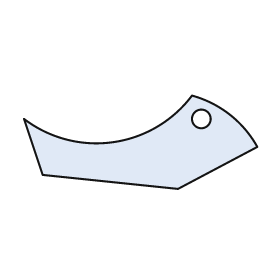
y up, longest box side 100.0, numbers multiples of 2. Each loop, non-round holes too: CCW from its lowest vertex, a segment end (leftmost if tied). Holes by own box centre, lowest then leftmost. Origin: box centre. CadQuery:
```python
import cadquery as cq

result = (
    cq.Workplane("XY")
    .moveTo(16.0, -20.0)
    .lineTo(50.0, -2.0)
    .threePointArc((38.0, 12.0), (22.0, 20.0))
    .threePointArc((-12.0, 0.0), (-50.0, 10.0))
    .lineTo(-42.0, -14.0)
    .close()
    .moveTo(26.0, 10.0)
    .circle(4.0)
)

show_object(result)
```